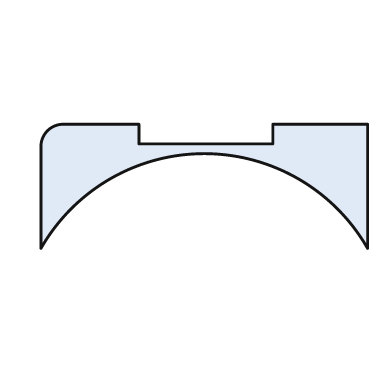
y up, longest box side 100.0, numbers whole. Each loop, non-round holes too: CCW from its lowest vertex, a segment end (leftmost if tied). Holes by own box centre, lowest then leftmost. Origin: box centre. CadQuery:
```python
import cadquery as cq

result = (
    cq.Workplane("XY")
    .moveTo(-50.0, -19.0)
    .threePointArc((0.0, 10.0), (50.0, -19.0))
    .lineTo(50.0, 19.0)
    .lineTo(21.0, 19.0)
    .lineTo(21.0, 13.0)
    .lineTo(-20.0, 13.0)
    .lineTo(-20.0, 19.0)
    .lineTo(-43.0, 19.0)
    .threePointArc((-48.0, 17.0), (-50.0, 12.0))
    .close()
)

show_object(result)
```